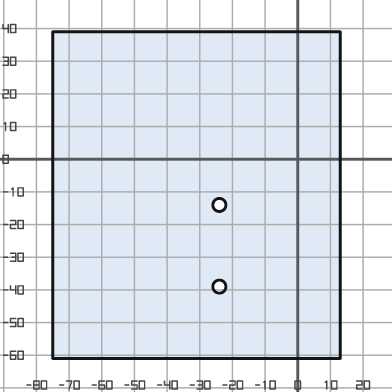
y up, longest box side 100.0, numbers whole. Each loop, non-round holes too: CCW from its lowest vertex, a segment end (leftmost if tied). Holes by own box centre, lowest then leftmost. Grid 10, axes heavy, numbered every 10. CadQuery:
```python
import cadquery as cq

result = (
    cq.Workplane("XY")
    .moveTo(-75.0, -61.0)
    .lineTo(13.0, -61.0)
    .lineTo(13.0, 39.0)
    .lineTo(-75.0, 39.0)
    .close()
    .moveTo(-24.0, -39.0)
    .circle(2.0)
    .moveTo(-24.0, -14.0)
    .circle(2.0)
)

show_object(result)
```